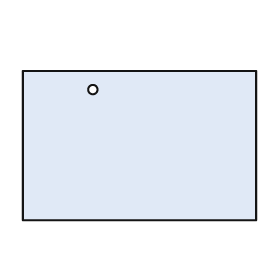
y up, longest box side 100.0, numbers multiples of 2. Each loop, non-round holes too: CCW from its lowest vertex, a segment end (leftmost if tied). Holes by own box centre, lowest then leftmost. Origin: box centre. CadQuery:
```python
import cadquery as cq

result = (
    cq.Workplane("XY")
    .moveTo(-50.0, -32.0)
    .lineTo(50.0, -32.0)
    .lineTo(50.0, 32.0)
    .lineTo(-50.0, 32.0)
    .close()
    .moveTo(-20.0, 24.0)
    .circle(2.0)
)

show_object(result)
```